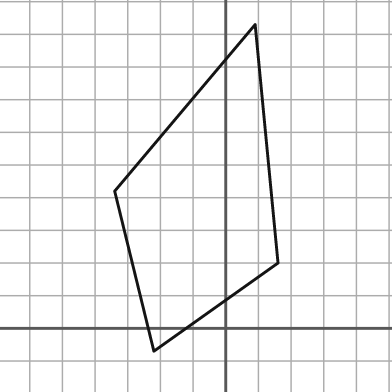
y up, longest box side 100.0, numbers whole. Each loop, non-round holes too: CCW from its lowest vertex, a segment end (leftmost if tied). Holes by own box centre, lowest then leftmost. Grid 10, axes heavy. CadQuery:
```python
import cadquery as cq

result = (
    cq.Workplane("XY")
    .moveTo(-22.0, -7.0)
    .lineTo(16.0, 20.0)
    .lineTo(9.0, 93.0)
    .lineTo(-34.0, 42.0)
    .close()
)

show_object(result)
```